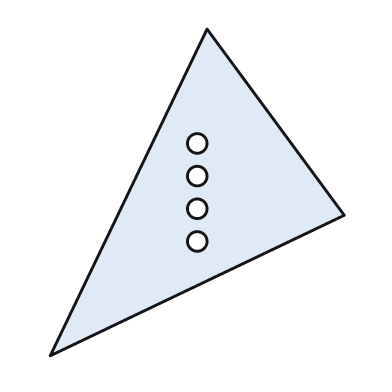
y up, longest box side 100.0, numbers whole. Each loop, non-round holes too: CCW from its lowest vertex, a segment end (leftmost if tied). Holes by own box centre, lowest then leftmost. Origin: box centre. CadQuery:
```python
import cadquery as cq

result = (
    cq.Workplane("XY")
    .moveTo(-45.0, -50.0)
    .lineTo(45.0, -7.0)
    .lineTo(3.0, 50.0)
    .close()
    .moveTo(0.0, -15.0)
    .circle(3.0)
    .moveTo(0.0, -5.0)
    .circle(3.0)
    .moveTo(0.0, 5.0)
    .circle(3.0)
    .moveTo(0.0, 15.0)
    .circle(3.0)
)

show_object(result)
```